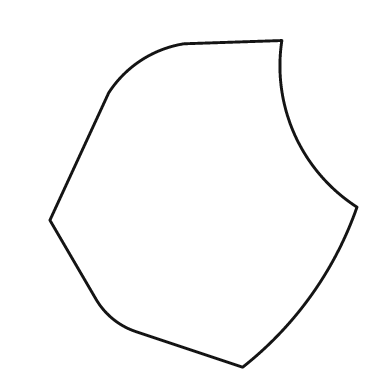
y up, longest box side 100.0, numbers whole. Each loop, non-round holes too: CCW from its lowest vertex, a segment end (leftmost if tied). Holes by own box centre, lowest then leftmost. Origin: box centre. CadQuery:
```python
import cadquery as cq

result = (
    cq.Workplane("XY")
    .moveTo(12.0, -50.0)
    .threePointArc((33.0, -28.0), (47.0, -1.0))
    .threePointArc((28.0, 21.0), (24.0, 50.0))
    .lineTo(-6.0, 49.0)
    .threePointArc((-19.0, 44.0), (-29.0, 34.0))
    .lineTo(-47.0, -5.0)
    .lineTo(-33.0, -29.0)
    .threePointArc((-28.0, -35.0), (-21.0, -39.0))
    .close()
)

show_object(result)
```